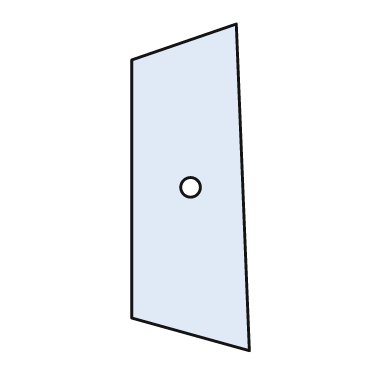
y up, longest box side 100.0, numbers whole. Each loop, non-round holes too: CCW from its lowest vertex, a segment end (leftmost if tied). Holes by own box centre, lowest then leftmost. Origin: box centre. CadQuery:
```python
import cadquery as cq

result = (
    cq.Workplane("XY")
    .moveTo(18.0, -50.0)
    .lineTo(14.0, 50.0)
    .lineTo(-18.0, 39.0)
    .lineTo(-18.0, -40.0)
    .close()
    .moveTo(0.0, 0.0)
    .circle(3.0)
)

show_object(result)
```